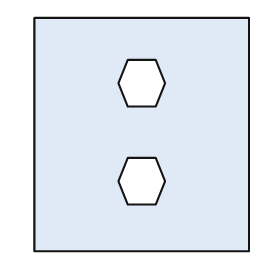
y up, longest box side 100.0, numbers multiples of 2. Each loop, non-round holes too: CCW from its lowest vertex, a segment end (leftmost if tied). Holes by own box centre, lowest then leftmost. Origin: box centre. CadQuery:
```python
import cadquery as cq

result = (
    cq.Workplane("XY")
    .moveTo(-46.0, -50.0)
    .lineTo(46.0, -50.0)
    .lineTo(46.0, 50.0)
    .lineTo(-46.0, 50.0)
    .close()
    .moveTo(-6.0, -30.0)
    .lineTo(6.0, -30.0)
    .lineTo(10.0, -20.0)
    .lineTo(6.0, -10.0)
    .lineTo(-6.0, -10.0)
    .lineTo(-10.0, -20.0)
    .close()
    .moveTo(-6.0, 12.0)
    .lineTo(6.0, 12.0)
    .lineTo(10.0, 22.0)
    .lineTo(6.0, 32.0)
    .lineTo(-6.0, 32.0)
    .lineTo(-10.0, 22.0)
    .close()
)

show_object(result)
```